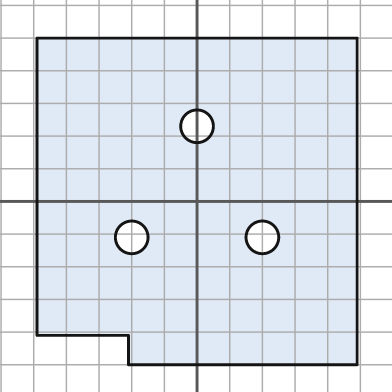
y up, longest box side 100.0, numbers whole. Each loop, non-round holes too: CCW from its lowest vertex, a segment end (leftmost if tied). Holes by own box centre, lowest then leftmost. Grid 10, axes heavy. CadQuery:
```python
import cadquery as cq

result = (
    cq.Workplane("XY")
    .moveTo(-21.0, -50.0)
    .lineTo(49.0, -50.0)
    .lineTo(49.0, 50.0)
    .lineTo(-49.0, 50.0)
    .lineTo(-49.0, -41.0)
    .lineTo(-21.0, -41.0)
    .close()
    .moveTo(-20.0, -11.0)
    .circle(5.0)
    .moveTo(20.0, -11.0)
    .circle(5.0)
    .moveTo(0.0, 23.0)
    .circle(5.0)
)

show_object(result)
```